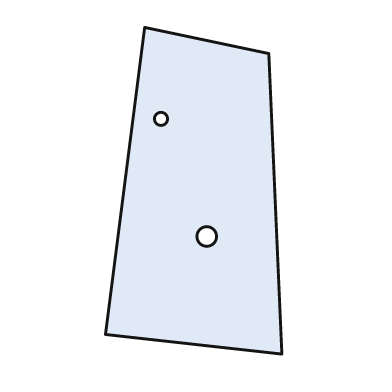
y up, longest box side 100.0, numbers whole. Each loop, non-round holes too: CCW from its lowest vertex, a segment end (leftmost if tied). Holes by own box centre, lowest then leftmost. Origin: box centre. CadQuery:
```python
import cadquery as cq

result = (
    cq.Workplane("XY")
    .moveTo(27.0, -50.0)
    .lineTo(23.0, 42.0)
    .lineTo(-15.0, 50.0)
    .lineTo(-27.0, -44.0)
    .close()
    .moveTo(4.0, -14.0)
    .circle(3.0)
    .moveTo(-10.0, 22.0)
    .circle(2.0)
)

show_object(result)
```